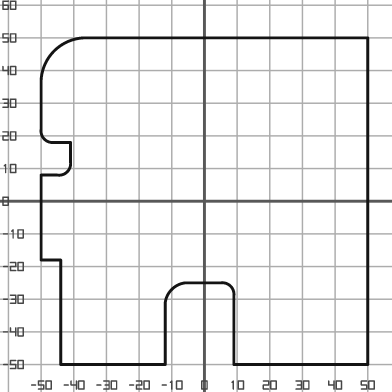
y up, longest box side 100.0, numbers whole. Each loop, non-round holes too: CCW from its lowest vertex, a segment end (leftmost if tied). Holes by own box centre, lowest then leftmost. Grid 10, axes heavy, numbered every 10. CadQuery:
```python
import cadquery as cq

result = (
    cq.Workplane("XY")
    .moveTo(-44.0, -50.0)
    .lineTo(-12.0, -50.0)
    .lineTo(-12.0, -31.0)
    .threePointArc((-10.0, -27.0), (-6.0, -25.0))
    .lineTo(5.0, -25.0)
    .threePointArc((8.0, -26.0), (9.0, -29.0))
    .lineTo(9.0, -50.0)
    .lineTo(50.0, -50.0)
    .lineTo(50.0, 50.0)
    .lineTo(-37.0, 50.0)
    .threePointArc((-46.0, 46.0), (-50.0, 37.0))
    .lineTo(-50.0, 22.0)
    .threePointArc((-49.0, 19.0), (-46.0, 18.0))
    .lineTo(-41.0, 18.0)
    .lineTo(-41.0, 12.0)
    .threePointArc((-42.0, 9.0), (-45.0, 8.0))
    .lineTo(-50.0, 8.0)
    .lineTo(-50.0, -18.0)
    .lineTo(-44.0, -18.0)
    .close()
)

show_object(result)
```